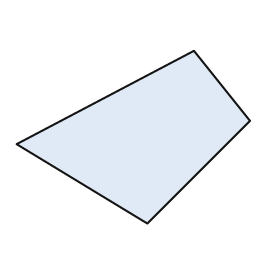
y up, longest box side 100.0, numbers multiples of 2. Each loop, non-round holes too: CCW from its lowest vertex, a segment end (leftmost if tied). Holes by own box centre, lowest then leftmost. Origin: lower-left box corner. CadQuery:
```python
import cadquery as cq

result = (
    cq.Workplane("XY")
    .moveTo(56.0, 0.0)
    .lineTo(100.0, 44.0)
    .lineTo(76.0, 74.0)
    .lineTo(0.0, 34.0)
    .close()
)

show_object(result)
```